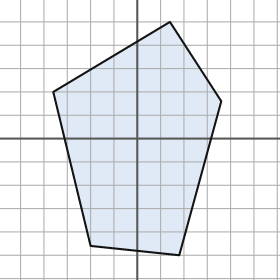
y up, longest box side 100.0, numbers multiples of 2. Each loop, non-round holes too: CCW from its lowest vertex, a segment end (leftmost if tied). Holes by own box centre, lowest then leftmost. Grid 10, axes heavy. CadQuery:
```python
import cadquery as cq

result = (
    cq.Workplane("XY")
    .moveTo(18.0, -50.0)
    .lineTo(36.0, 16.0)
    .lineTo(14.0, 50.0)
    .lineTo(-36.0, 20.0)
    .lineTo(-20.0, -46.0)
    .close()
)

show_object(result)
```